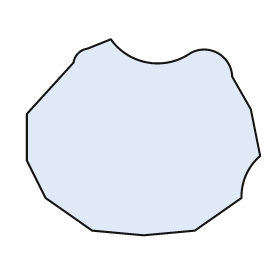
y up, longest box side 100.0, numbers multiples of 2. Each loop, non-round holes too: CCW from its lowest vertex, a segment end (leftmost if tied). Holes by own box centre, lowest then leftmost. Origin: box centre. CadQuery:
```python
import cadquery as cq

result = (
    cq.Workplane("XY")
    .moveTo(0.0, -42.0)
    .lineTo(22.0, -40.0)
    .lineTo(42.0, -26.0)
    .threePointArc((44.0, -16.0), (50.0, -8.0))
    .lineTo(46.0, 12.0)
    .lineTo(38.0, 26.0)
    .threePointArc((32.0, 36.0), (20.0, 36.0))
    .threePointArc((2.0, 32.0), (-14.0, 42.0))
    .lineTo(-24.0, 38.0)
    .threePointArc((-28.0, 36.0), (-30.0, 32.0))
    .lineTo(-50.0, 10.0)
    .lineTo(-50.0, -10.0)
    .lineTo(-42.0, -26.0)
    .lineTo(-22.0, -40.0)
    .close()
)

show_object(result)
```